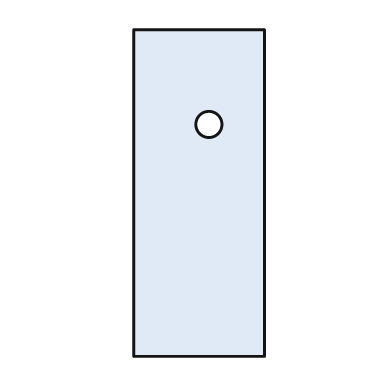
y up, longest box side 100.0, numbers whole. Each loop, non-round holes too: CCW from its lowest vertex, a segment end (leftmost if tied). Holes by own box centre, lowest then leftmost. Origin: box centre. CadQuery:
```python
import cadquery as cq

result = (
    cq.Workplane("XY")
    .moveTo(-20.0, -50.0)
    .lineTo(20.0, -50.0)
    .lineTo(20.0, 50.0)
    .lineTo(-20.0, 50.0)
    .close()
    .moveTo(3.0, 21.0)
    .circle(4.0)
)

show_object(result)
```